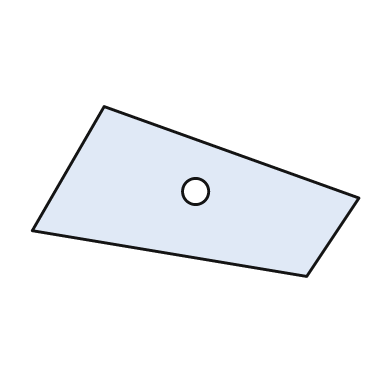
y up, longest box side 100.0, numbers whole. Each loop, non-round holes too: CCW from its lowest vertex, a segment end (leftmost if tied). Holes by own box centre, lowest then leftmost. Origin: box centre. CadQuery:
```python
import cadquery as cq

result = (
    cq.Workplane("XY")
    .moveTo(34.0, -26.0)
    .lineTo(50.0, -2.0)
    .lineTo(-28.0, 26.0)
    .lineTo(-50.0, -12.0)
    .close()
    .moveTo(0.0, 0.0)
    .circle(4.0)
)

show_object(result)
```